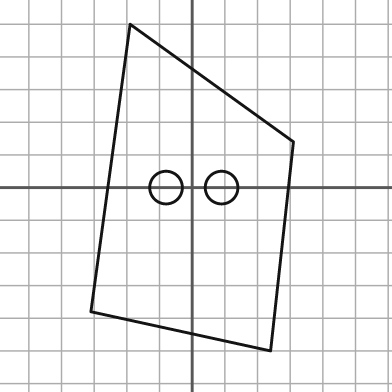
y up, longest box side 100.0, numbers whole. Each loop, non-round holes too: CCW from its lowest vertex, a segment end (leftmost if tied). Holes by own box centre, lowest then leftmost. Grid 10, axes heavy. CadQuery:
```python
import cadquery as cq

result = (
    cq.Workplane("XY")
    .moveTo(24.0, -50.0)
    .lineTo(31.0, 14.0)
    .lineTo(-19.0, 50.0)
    .lineTo(-31.0, -38.0)
    .close()
    .moveTo(-8.0, 0.0)
    .circle(5.0)
    .moveTo(9.0, 0.0)
    .circle(5.0)
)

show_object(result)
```